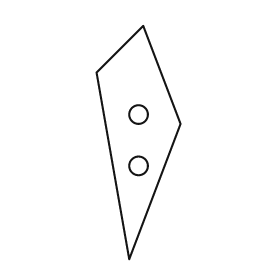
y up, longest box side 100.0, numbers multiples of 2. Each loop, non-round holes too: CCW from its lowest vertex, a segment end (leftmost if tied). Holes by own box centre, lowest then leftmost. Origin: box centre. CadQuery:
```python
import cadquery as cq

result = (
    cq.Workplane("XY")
    .moveTo(-4.0, -50.0)
    .lineTo(18.0, 8.0)
    .lineTo(2.0, 50.0)
    .lineTo(-18.0, 30.0)
    .close()
    .moveTo(0.0, -10.0)
    .circle(4.0)
    .moveTo(0.0, 12.0)
    .circle(4.0)
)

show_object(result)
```